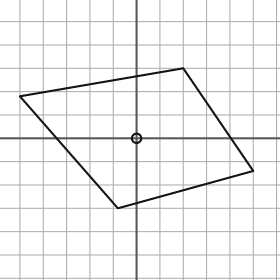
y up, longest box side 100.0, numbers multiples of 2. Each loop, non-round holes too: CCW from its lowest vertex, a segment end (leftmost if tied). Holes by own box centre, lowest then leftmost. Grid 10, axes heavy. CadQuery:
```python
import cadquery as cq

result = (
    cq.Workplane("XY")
    .moveTo(-8.0, -30.0)
    .lineTo(50.0, -14.0)
    .lineTo(20.0, 30.0)
    .lineTo(-50.0, 18.0)
    .close()
    .moveTo(0.0, 0.0)
    .circle(2.0)
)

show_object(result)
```